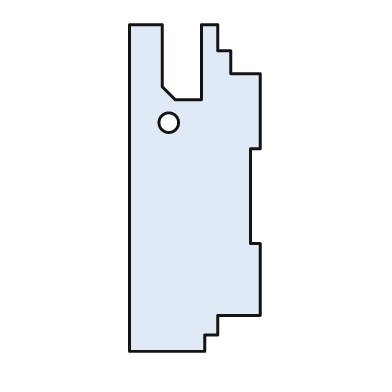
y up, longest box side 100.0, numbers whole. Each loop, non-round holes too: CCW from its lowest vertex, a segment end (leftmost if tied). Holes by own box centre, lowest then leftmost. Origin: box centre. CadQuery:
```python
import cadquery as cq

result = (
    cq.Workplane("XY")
    .moveTo(-20.0, -50.0)
    .lineTo(3.0, -50.0)
    .lineTo(3.0, -45.0)
    .lineTo(7.0, -45.0)
    .lineTo(7.0, -39.0)
    .lineTo(20.0, -39.0)
    .lineTo(20.0, -17.0)
    .lineTo(17.0, -17.0)
    .lineTo(17.0, 12.0)
    .lineTo(20.0, 12.0)
    .lineTo(20.0, 35.0)
    .lineTo(11.0, 35.0)
    .lineTo(11.0, 42.0)
    .lineTo(7.0, 42.0)
    .lineTo(7.0, 50.0)
    .lineTo(2.0, 50.0)
    .lineTo(2.0, 27.0)
    .lineTo(-6.0, 27.0)
    .lineTo(-10.0, 31.0)
    .lineTo(-10.0, 50.0)
    .lineTo(-20.0, 50.0)
    .close()
    .moveTo(-8.0, 20.0)
    .circle(3.0)
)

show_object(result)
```